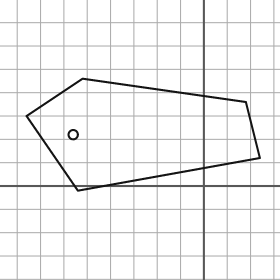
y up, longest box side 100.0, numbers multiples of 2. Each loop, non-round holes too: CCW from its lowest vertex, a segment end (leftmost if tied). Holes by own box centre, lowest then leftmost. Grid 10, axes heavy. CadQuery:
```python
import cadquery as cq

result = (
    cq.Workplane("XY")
    .moveTo(-54.0, -2.0)
    .lineTo(24.0, 12.0)
    .lineTo(18.0, 36.0)
    .lineTo(-52.0, 46.0)
    .lineTo(-76.0, 30.0)
    .close()
    .moveTo(-56.0, 22.0)
    .circle(2.0)
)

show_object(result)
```